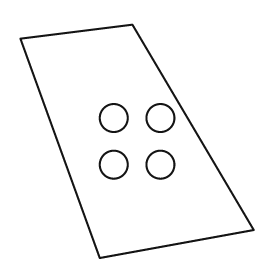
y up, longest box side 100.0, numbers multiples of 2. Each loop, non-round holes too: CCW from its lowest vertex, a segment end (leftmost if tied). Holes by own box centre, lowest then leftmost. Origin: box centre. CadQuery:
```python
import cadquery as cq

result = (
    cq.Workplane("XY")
    .moveTo(-16.0, -50.0)
    .lineTo(50.0, -38.0)
    .lineTo(-2.0, 50.0)
    .lineTo(-50.0, 44.0)
    .close()
    .moveTo(-10.0, -10.0)
    .circle(6.0)
    .moveTo(10.0, -10.0)
    .circle(6.0)
    .moveTo(-10.0, 10.0)
    .circle(6.0)
    .moveTo(10.0, 10.0)
    .circle(6.0)
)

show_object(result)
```